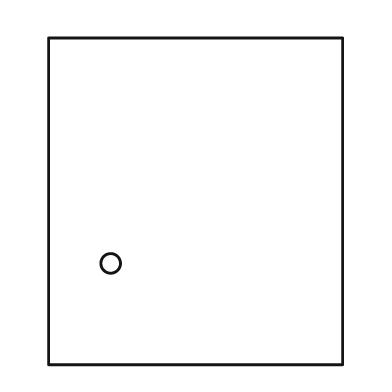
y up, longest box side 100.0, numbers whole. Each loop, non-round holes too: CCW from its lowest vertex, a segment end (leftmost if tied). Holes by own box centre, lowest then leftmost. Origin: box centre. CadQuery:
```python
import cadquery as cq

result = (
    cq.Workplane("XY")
    .moveTo(-45.0, -50.0)
    .lineTo(45.0, -50.0)
    .lineTo(45.0, 50.0)
    .lineTo(-45.0, 50.0)
    .close()
    .moveTo(-26.0, -19.0)
    .circle(3.0)
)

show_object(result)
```